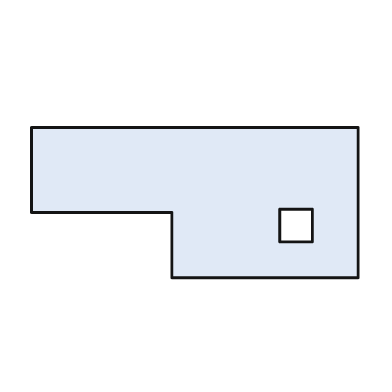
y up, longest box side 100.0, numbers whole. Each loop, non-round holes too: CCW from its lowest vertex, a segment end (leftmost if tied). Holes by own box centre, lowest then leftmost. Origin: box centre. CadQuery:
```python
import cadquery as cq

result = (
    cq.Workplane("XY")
    .moveTo(-7.0, -23.0)
    .lineTo(50.0, -23.0)
    .lineTo(50.0, 23.0)
    .lineTo(-50.0, 23.0)
    .lineTo(-50.0, -3.0)
    .lineTo(-7.0, -3.0)
    .close()
    .moveTo(26.0, -12.0)
    .lineTo(36.0, -12.0)
    .lineTo(36.0, -2.0)
    .lineTo(26.0, -2.0)
    .close()
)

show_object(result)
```